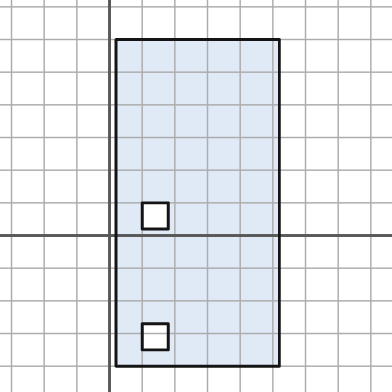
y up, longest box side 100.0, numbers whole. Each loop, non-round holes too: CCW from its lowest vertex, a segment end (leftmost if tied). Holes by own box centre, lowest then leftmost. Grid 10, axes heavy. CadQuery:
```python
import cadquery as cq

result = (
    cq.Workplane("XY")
    .moveTo(2.0, -40.0)
    .lineTo(52.0, -40.0)
    .lineTo(52.0, 60.0)
    .lineTo(2.0, 60.0)
    .close()
    .moveTo(10.0, -35.0)
    .lineTo(18.0, -35.0)
    .lineTo(18.0, -27.0)
    .lineTo(10.0, -27.0)
    .close()
    .moveTo(10.0, 2.0)
    .lineTo(18.0, 2.0)
    .lineTo(18.0, 10.0)
    .lineTo(10.0, 10.0)
    .close()
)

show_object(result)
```